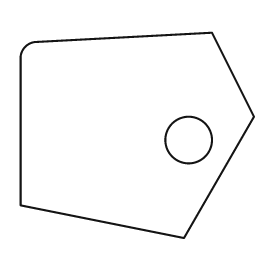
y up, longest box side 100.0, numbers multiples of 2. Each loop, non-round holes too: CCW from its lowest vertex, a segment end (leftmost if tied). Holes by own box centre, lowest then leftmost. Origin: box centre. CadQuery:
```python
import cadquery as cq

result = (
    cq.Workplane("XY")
    .moveTo(20.0, -44.0)
    .lineTo(50.0, 8.0)
    .lineTo(32.0, 44.0)
    .lineTo(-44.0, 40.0)
    .threePointArc((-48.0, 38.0), (-50.0, 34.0))
    .lineTo(-50.0, -30.0)
    .close()
    .moveTo(22.0, -2.0)
    .circle(10.0)
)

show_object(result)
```